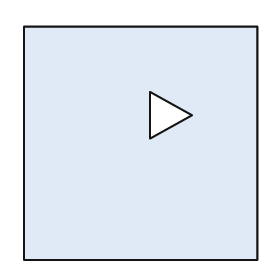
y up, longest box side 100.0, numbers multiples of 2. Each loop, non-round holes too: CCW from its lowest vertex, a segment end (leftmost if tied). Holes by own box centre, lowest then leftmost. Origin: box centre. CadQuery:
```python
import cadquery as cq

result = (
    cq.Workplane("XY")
    .moveTo(-50.0, -50.0)
    .lineTo(50.0, -50.0)
    .lineTo(50.0, 50.0)
    .lineTo(-50.0, 50.0)
    .close()
    .moveTo(4.0, 2.0)
    .lineTo(22.0, 12.0)
    .lineTo(4.0, 22.0)
    .close()
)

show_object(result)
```